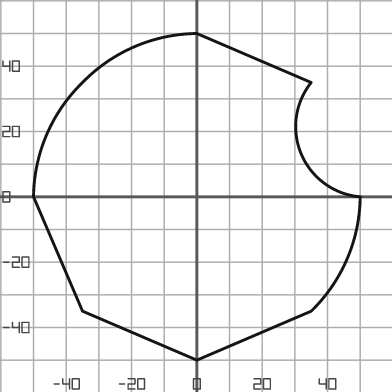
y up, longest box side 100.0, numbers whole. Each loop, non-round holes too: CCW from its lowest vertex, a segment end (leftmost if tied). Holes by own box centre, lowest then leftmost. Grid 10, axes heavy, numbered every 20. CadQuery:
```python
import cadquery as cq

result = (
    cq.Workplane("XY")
    .moveTo(0.0, -50.0)
    .lineTo(35.0, -35.0)
    .threePointArc((46.0, -19.0), (50.0, 0.0))
    .threePointArc((32.0, 13.0), (35.0, 35.0))
    .lineTo(0.0, 50.0)
    .threePointArc((-19.0, 46.0), (-35.0, 35.0))
    .threePointArc((-46.0, 19.0), (-50.0, 0.0))
    .lineTo(-35.0, -35.0)
    .close()
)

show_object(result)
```